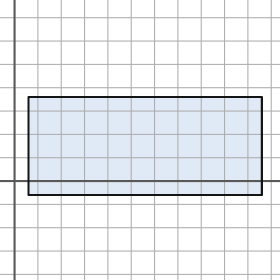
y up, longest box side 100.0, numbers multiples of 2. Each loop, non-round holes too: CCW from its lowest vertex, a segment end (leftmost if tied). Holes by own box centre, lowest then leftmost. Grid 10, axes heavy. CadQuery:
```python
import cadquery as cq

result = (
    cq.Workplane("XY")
    .moveTo(6.0, -6.0)
    .lineTo(106.0, -6.0)
    .lineTo(106.0, 36.0)
    .lineTo(6.0, 36.0)
    .close()
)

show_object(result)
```